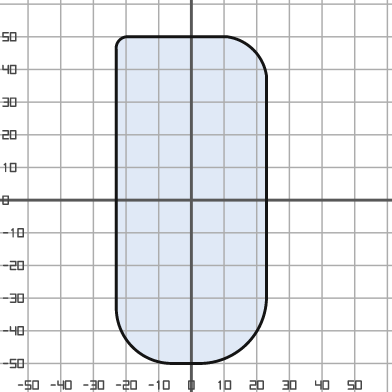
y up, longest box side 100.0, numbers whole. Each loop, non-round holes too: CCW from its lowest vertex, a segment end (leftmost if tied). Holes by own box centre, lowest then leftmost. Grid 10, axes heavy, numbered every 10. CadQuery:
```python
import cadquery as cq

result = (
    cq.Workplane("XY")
    .moveTo(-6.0, -50.0)
    .lineTo(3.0, -50.0)
    .threePointArc((17.0, -44.0), (23.0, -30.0))
    .lineTo(23.0, 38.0)
    .threePointArc((19.0, 46.0), (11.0, 50.0))
    .lineTo(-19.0, 50.0)
    .threePointArc((-22.0, 49.0), (-23.0, 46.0))
    .lineTo(-23.0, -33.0)
    .threePointArc((-18.0, -45.0), (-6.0, -50.0))
    .close()
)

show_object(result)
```